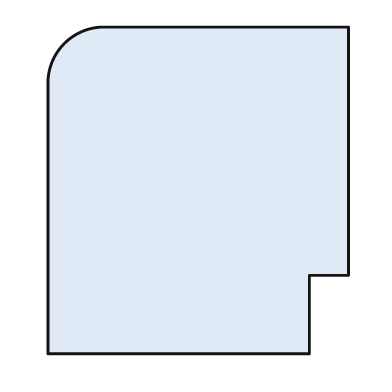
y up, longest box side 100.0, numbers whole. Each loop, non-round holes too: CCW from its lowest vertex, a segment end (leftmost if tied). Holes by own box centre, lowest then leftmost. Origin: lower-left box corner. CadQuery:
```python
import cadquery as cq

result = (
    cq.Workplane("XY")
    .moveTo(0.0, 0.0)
    .lineTo(80.0, 0.0)
    .lineTo(80.0, 24.0)
    .lineTo(92.0, 24.0)
    .lineTo(92.0, 100.0)
    .lineTo(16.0, 100.0)
    .threePointArc((5.0, 95.0), (0.0, 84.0))
    .close()
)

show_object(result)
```